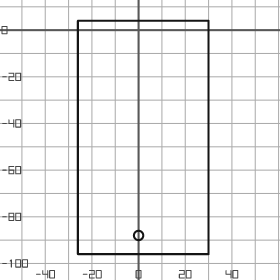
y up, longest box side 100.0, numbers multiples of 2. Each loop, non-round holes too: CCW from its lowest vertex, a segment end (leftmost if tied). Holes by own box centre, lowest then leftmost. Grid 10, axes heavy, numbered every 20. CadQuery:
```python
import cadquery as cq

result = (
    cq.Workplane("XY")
    .moveTo(-26.0, -96.0)
    .lineTo(30.0, -96.0)
    .lineTo(30.0, 4.0)
    .lineTo(-26.0, 4.0)
    .close()
    .moveTo(0.0, -88.0)
    .circle(2.0)
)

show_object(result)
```